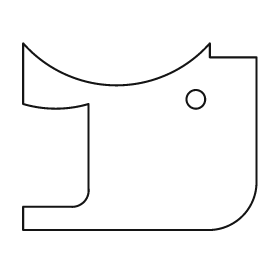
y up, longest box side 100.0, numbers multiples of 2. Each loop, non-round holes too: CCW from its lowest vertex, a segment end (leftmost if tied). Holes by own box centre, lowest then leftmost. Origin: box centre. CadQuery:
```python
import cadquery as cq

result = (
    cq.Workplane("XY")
    .moveTo(-50.0, -40.0)
    .lineTo(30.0, -40.0)
    .threePointArc((44.0, -34.0), (50.0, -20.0))
    .lineTo(50.0, 34.0)
    .lineTo(30.0, 34.0)
    .lineTo(30.0, 40.0)
    .threePointArc((-10.0, 22.0), (-50.0, 40.0))
    .lineTo(-50.0, 14.0)
    .threePointArc((-36.0, 12.0), (-22.0, 14.0))
    .lineTo(-22.0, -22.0)
    .threePointArc((-24.0, -28.0), (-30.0, -30.0))
    .lineTo(-50.0, -30.0)
    .close()
    .moveTo(24.0, 16.0)
    .circle(4.0)
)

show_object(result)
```